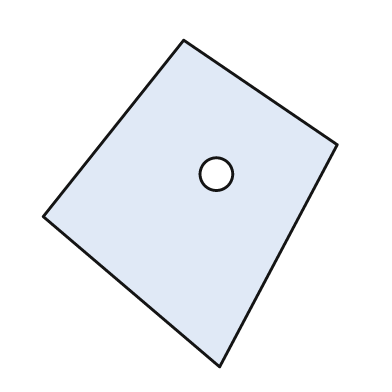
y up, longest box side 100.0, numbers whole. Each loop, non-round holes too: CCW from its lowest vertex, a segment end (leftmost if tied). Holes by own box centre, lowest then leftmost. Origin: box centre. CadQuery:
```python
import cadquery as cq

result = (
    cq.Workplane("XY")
    .moveTo(9.0, -50.0)
    .lineTo(45.0, 18.0)
    .lineTo(-2.0, 50.0)
    .lineTo(-45.0, -4.0)
    .close()
    .moveTo(8.0, 9.0)
    .circle(5.0)
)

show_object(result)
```